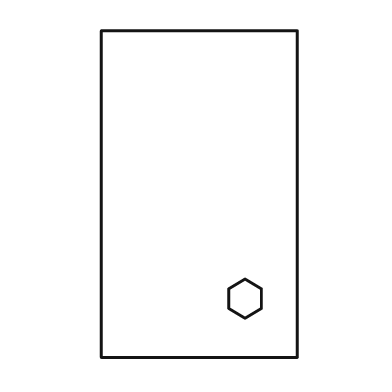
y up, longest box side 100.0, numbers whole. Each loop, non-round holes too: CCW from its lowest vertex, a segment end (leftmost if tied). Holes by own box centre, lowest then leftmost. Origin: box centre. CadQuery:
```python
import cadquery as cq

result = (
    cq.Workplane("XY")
    .moveTo(-30.0, -50.0)
    .lineTo(30.0, -50.0)
    .lineTo(30.0, 50.0)
    .lineTo(-30.0, 50.0)
    .close()
    .moveTo(14.0, -38.0)
    .lineTo(19.0, -35.0)
    .lineTo(19.0, -29.0)
    .lineTo(14.0, -26.0)
    .lineTo(9.0, -29.0)
    .lineTo(9.0, -35.0)
    .close()
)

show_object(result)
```